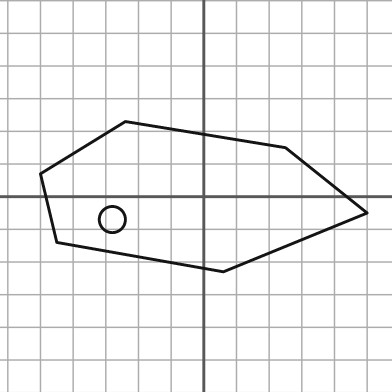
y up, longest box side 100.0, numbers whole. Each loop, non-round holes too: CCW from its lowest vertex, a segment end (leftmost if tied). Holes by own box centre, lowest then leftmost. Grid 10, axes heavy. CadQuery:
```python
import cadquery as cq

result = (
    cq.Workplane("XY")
    .moveTo(6.0, -23.0)
    .lineTo(50.0, -5.0)
    .lineTo(25.0, 15.0)
    .lineTo(-24.0, 23.0)
    .lineTo(-50.0, 7.0)
    .lineTo(-45.0, -14.0)
    .close()
    .moveTo(-28.0, -7.0)
    .circle(4.0)
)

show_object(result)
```